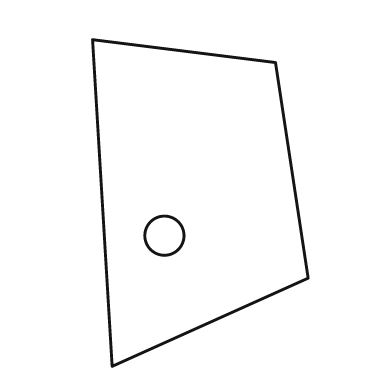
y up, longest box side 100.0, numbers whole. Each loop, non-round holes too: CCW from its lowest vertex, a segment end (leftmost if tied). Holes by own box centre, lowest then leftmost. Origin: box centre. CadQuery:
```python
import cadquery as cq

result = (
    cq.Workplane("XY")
    .moveTo(-27.0, -50.0)
    .lineTo(33.0, -23.0)
    .lineTo(23.0, 43.0)
    .lineTo(-33.0, 50.0)
    .close()
    .moveTo(-11.0, -10.0)
    .circle(6.0)
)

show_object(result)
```